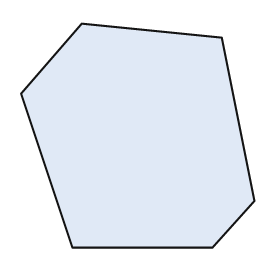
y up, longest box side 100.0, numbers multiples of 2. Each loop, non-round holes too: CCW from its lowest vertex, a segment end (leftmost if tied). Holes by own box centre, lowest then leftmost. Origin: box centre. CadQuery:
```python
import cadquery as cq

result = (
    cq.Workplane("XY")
    .moveTo(-28.0, -48.0)
    .lineTo(32.0, -48.0)
    .lineTo(50.0, -28.0)
    .lineTo(36.0, 42.0)
    .lineTo(-24.0, 48.0)
    .lineTo(-50.0, 18.0)
    .close()
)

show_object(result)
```